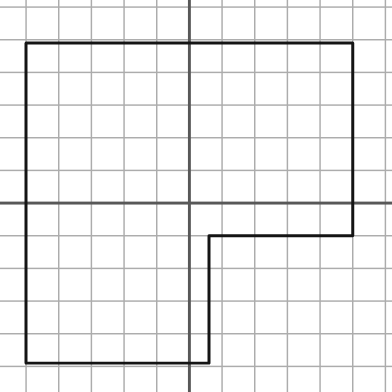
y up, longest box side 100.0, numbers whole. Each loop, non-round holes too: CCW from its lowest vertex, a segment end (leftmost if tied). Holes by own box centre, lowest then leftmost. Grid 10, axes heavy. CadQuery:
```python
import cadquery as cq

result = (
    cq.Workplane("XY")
    .moveTo(-50.0, -49.0)
    .lineTo(6.0, -49.0)
    .lineTo(6.0, -10.0)
    .lineTo(50.0, -10.0)
    .lineTo(50.0, 49.0)
    .lineTo(-50.0, 49.0)
    .close()
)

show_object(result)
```